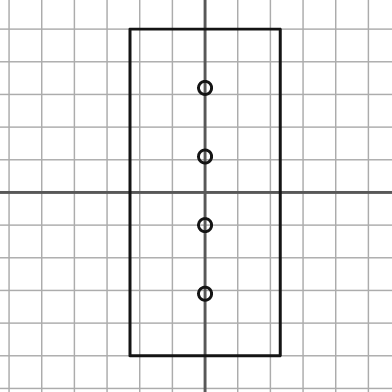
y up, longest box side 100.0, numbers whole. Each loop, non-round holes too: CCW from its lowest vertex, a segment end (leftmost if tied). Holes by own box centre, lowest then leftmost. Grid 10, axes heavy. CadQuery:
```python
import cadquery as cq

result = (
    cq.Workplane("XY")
    .moveTo(-23.0, -50.0)
    .lineTo(23.0, -50.0)
    .lineTo(23.0, 50.0)
    .lineTo(-23.0, 50.0)
    .close()
    .moveTo(0.0, -31.0)
    .circle(2.0)
    .moveTo(0.0, -10.0)
    .circle(2.0)
    .moveTo(0.0, 11.0)
    .circle(2.0)
    .moveTo(0.0, 32.0)
    .circle(2.0)
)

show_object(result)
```